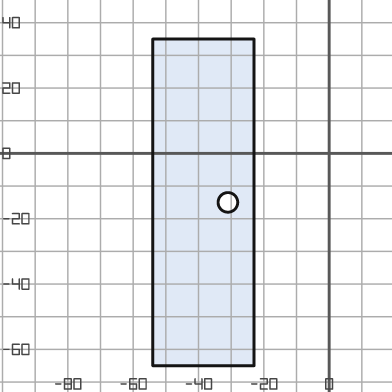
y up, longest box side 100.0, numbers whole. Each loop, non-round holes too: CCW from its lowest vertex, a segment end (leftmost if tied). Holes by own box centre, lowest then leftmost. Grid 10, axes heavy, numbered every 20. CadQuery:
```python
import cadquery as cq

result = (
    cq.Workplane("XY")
    .moveTo(-54.0, -65.0)
    .lineTo(-23.0, -65.0)
    .lineTo(-23.0, 35.0)
    .lineTo(-54.0, 35.0)
    .close()
    .moveTo(-31.0, -15.0)
    .circle(3.0)
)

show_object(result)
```